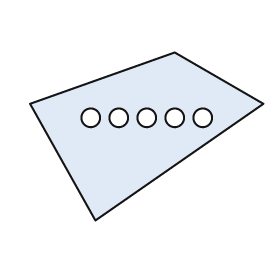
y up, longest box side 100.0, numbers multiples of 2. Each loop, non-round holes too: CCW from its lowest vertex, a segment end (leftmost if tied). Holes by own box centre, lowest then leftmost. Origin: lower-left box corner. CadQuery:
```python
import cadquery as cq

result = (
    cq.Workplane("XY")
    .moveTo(28.0, 0.0)
    .lineTo(100.0, 50.0)
    .lineTo(62.0, 72.0)
    .lineTo(0.0, 50.0)
    .close()
    .moveTo(26.0, 44.0)
    .circle(4.0)
    .moveTo(38.0, 44.0)
    .circle(4.0)
    .moveTo(50.0, 44.0)
    .circle(4.0)
    .moveTo(62.0, 44.0)
    .circle(4.0)
    .moveTo(74.0, 44.0)
    .circle(4.0)
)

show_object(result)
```